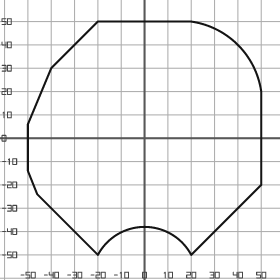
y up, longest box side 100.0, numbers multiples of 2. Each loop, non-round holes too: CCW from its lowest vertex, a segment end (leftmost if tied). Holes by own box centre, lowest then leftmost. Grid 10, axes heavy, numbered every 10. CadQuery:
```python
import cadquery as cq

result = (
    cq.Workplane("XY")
    .moveTo(-20.0, -50.0)
    .threePointArc((0.0, -38.0), (20.0, -50.0))
    .lineTo(50.0, -20.0)
    .lineTo(50.0, 20.0)
    .threePointArc((40.0, 40.0), (20.0, 50.0))
    .lineTo(-20.0, 50.0)
    .lineTo(-40.0, 30.0)
    .lineTo(-50.0, 6.0)
    .lineTo(-50.0, -14.0)
    .lineTo(-46.0, -24.0)
    .close()
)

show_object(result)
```